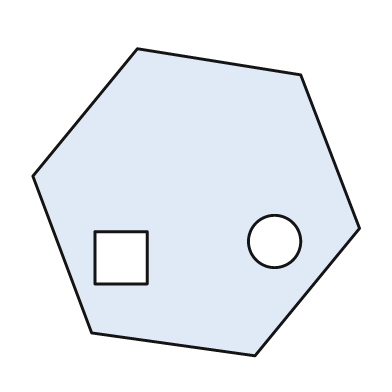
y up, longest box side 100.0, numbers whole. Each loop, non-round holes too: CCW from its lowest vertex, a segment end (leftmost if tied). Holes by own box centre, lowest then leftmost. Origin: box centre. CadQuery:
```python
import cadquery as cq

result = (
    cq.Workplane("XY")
    .moveTo(18.0, -47.0)
    .lineTo(50.0, -8.0)
    .lineTo(32.0, 39.0)
    .lineTo(-18.0, 47.0)
    .lineTo(-50.0, 8.0)
    .lineTo(-32.0, -40.0)
    .close()
    .moveTo(-31.0, -25.0)
    .lineTo(-15.0, -25.0)
    .lineTo(-15.0, -9.0)
    .lineTo(-31.0, -9.0)
    .close()
    .moveTo(24.0, -12.0)
    .circle(8.0)
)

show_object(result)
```